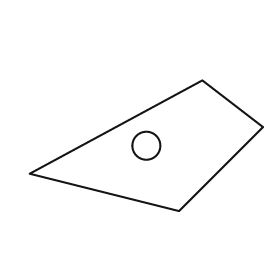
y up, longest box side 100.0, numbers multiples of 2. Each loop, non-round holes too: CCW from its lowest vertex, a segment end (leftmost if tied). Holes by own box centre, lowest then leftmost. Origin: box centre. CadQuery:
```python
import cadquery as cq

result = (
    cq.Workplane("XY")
    .moveTo(14.0, -28.0)
    .lineTo(50.0, 8.0)
    .lineTo(24.0, 28.0)
    .lineTo(-50.0, -12.0)
    .close()
    .moveTo(0.0, 0.0)
    .circle(6.0)
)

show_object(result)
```